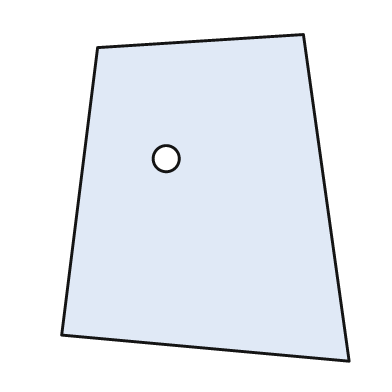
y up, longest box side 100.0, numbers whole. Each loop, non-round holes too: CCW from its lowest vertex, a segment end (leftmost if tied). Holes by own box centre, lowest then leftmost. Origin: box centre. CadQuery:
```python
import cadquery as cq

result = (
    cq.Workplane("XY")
    .moveTo(44.0, -50.0)
    .lineTo(30.0, 50.0)
    .lineTo(-33.0, 46.0)
    .lineTo(-44.0, -42.0)
    .close()
    .moveTo(-12.0, 12.0)
    .circle(4.0)
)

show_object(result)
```